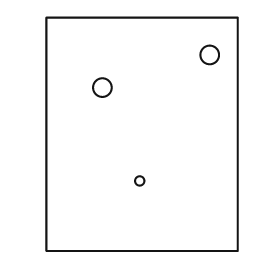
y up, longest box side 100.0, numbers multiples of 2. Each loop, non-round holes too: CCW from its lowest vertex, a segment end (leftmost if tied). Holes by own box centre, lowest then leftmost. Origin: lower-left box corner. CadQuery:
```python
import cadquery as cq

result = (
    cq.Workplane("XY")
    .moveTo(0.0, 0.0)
    .lineTo(82.0, 0.0)
    .lineTo(82.0, 100.0)
    .lineTo(0.0, 100.0)
    .close()
    .moveTo(40.0, 30.0)
    .circle(2.0)
    .moveTo(24.0, 70.0)
    .circle(4.0)
    .moveTo(70.0, 84.0)
    .circle(4.0)
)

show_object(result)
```